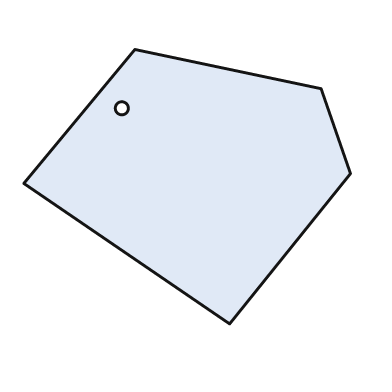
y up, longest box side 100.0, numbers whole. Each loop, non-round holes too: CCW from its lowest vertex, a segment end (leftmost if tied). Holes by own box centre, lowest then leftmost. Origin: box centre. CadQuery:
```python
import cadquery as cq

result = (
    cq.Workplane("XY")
    .moveTo(13.0, -42.0)
    .lineTo(50.0, 4.0)
    .lineTo(41.0, 30.0)
    .lineTo(-16.0, 42.0)
    .lineTo(-50.0, 1.0)
    .close()
    .moveTo(-20.0, 24.0)
    .circle(2.0)
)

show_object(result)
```